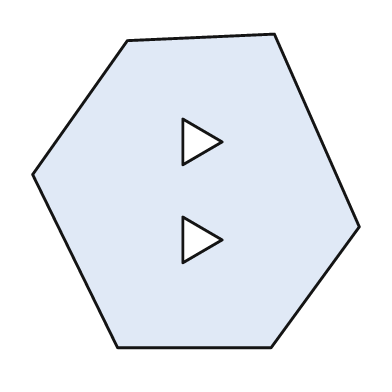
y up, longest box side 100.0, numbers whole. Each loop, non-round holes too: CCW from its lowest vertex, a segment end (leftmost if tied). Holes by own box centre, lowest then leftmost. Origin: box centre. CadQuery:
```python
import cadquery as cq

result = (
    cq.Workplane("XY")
    .moveTo(-24.0, -48.0)
    .lineTo(23.0, -48.0)
    .lineTo(50.0, -11.0)
    .lineTo(24.0, 48.0)
    .lineTo(-21.0, 46.0)
    .lineTo(-50.0, 5.0)
    .close()
    .moveTo(-4.0, -22.0)
    .lineTo(8.0, -15.0)
    .lineTo(-4.0, -8.0)
    .close()
    .moveTo(-4.0, 8.0)
    .lineTo(8.0, 15.0)
    .lineTo(-4.0, 22.0)
    .close()
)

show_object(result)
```